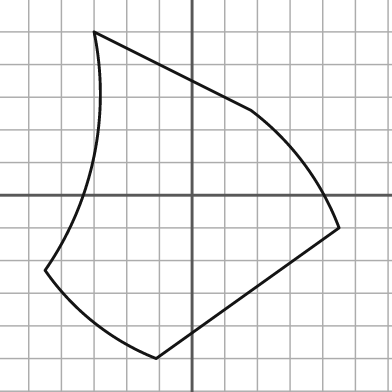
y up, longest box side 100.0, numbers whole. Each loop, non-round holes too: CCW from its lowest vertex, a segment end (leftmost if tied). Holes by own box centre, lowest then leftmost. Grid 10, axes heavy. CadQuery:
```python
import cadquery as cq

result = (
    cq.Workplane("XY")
    .moveTo(-11.0, -50.0)
    .lineTo(45.0, -10.0)
    .threePointArc((34.0, 10.0), (18.0, 26.0))
    .lineTo(-30.0, 50.0)
    .threePointArc((-30.0, 12.0), (-45.0, -23.0))
    .threePointArc((-30.0, -39.0), (-11.0, -50.0))
    .close()
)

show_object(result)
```